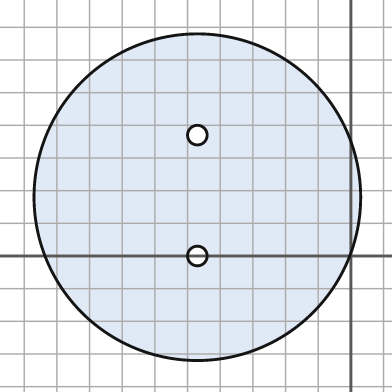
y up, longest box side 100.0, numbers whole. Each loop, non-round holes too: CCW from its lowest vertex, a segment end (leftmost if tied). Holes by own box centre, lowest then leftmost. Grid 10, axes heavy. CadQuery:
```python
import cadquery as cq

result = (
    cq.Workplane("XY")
    .moveTo(-47.0, 18.0)
    .circle(50.0)
    .moveTo(-47.0, 0.0)
    .circle(3.0)
    .moveTo(-47.0, 37.0)
    .circle(3.0)
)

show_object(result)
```